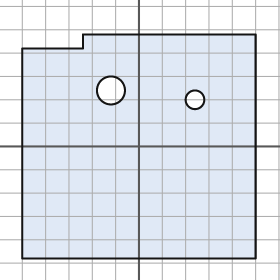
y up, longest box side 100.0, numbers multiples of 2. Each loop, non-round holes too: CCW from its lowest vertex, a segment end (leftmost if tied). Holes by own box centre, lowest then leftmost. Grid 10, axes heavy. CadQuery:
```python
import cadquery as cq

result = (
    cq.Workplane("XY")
    .moveTo(-50.0, -48.0)
    .lineTo(50.0, -48.0)
    .lineTo(50.0, 48.0)
    .lineTo(-24.0, 48.0)
    .lineTo(-24.0, 42.0)
    .lineTo(-50.0, 42.0)
    .close()
    .moveTo(24.0, 20.0)
    .circle(4.0)
    .moveTo(-12.0, 24.0)
    .circle(6.0)
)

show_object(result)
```